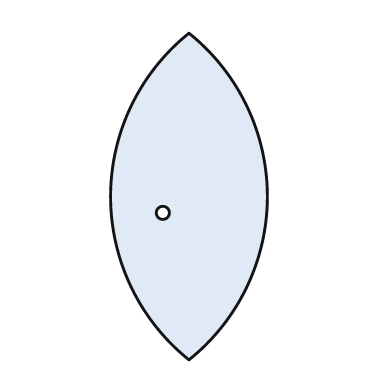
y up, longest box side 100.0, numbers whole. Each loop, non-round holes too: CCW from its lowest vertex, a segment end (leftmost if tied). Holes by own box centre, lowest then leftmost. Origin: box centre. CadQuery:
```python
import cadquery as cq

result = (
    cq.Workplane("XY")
    .moveTo(0.0, -50.0)
    .threePointArc((24.0, 0.0), (0.0, 50.0))
    .threePointArc((-24.0, 0.0), (0.0, -50.0))
    .close()
    .moveTo(-8.0, -5.0)
    .circle(2.0)
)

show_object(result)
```